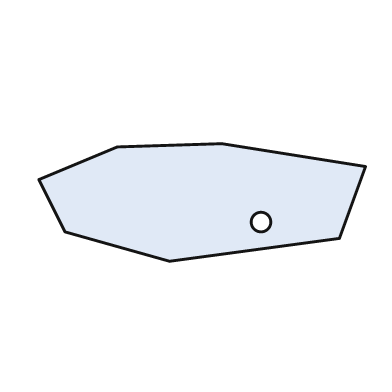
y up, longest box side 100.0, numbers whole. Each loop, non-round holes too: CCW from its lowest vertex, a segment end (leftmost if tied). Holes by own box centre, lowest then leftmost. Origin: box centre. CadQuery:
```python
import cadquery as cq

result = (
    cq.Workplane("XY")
    .moveTo(-10.0, -18.0)
    .lineTo(42.0, -11.0)
    .lineTo(50.0, 11.0)
    .lineTo(6.0, 18.0)
    .lineTo(-26.0, 17.0)
    .lineTo(-50.0, 7.0)
    .lineTo(-42.0, -9.0)
    .close()
    .moveTo(18.0, -6.0)
    .circle(3.0)
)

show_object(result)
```